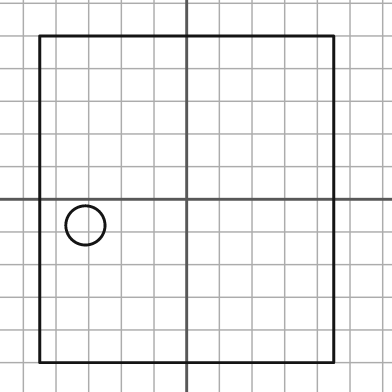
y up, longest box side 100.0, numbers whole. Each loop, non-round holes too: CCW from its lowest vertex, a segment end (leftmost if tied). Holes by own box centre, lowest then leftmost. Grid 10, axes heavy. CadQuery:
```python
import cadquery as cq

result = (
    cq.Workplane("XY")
    .moveTo(-45.0, -50.0)
    .lineTo(45.0, -50.0)
    .lineTo(45.0, 50.0)
    .lineTo(-45.0, 50.0)
    .close()
    .moveTo(-31.0, -8.0)
    .circle(6.0)
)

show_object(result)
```